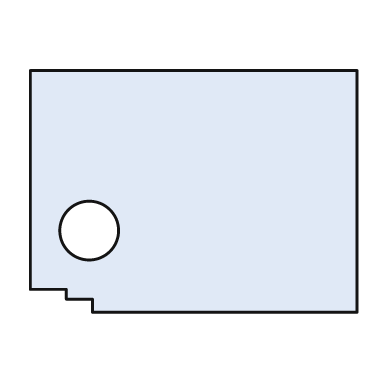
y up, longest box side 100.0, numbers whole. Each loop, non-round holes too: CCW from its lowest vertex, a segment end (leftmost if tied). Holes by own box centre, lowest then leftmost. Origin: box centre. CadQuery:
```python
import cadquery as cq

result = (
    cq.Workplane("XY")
    .moveTo(-31.0, -37.0)
    .lineTo(50.0, -37.0)
    .lineTo(50.0, 37.0)
    .lineTo(-50.0, 37.0)
    .lineTo(-50.0, -30.0)
    .lineTo(-39.0, -30.0)
    .lineTo(-39.0, -33.0)
    .lineTo(-31.0, -33.0)
    .close()
    .moveTo(-32.0, -12.0)
    .circle(9.0)
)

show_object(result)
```